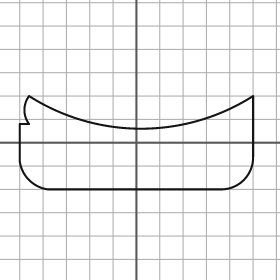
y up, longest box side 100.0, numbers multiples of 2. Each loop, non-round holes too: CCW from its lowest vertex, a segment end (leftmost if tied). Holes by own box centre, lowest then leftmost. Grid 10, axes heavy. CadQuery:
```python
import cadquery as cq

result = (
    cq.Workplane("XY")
    .moveTo(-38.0, -20.0)
    .lineTo(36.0, -20.0)
    .threePointArc((46.0, -16.0), (50.0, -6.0))
    .lineTo(50.0, 20.0)
    .threePointArc((2.0, 6.0), (-46.0, 20.0))
    .threePointArc((-48.0, 14.0), (-46.0, 8.0))
    .lineTo(-50.0, 8.0)
    .lineTo(-50.0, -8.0)
    .threePointArc((-46.0, -16.0), (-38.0, -20.0))
    .close()
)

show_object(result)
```